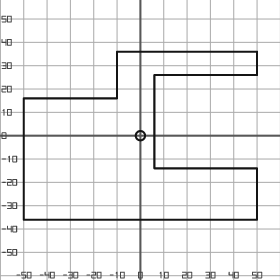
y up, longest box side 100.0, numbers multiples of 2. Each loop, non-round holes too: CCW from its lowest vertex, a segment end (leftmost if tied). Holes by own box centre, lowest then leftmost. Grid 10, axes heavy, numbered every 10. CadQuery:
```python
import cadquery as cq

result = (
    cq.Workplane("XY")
    .moveTo(-50.0, -36.0)
    .lineTo(50.0, -36.0)
    .lineTo(50.0, -14.0)
    .lineTo(6.0, -14.0)
    .lineTo(6.0, 26.0)
    .lineTo(50.0, 26.0)
    .lineTo(50.0, 36.0)
    .lineTo(-10.0, 36.0)
    .lineTo(-10.0, 16.0)
    .lineTo(-50.0, 16.0)
    .close()
    .moveTo(0.0, 0.0)
    .circle(2.0)
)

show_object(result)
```